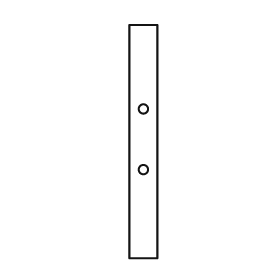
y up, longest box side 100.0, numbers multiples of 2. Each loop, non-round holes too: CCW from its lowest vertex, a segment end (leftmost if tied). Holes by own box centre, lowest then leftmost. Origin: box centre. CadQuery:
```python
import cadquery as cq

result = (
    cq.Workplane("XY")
    .moveTo(-6.0, -50.0)
    .lineTo(6.0, -50.0)
    .lineTo(6.0, 50.0)
    .lineTo(-6.0, 50.0)
    .close()
    .moveTo(0.0, -12.0)
    .circle(2.0)
    .moveTo(0.0, 14.0)
    .circle(2.0)
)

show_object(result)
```